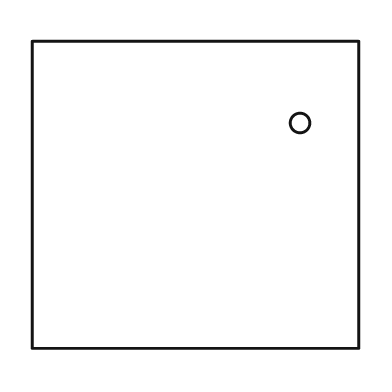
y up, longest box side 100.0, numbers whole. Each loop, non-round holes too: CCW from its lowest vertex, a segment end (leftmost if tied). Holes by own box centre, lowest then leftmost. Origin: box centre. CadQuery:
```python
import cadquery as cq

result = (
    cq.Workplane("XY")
    .moveTo(-50.0, -47.0)
    .lineTo(50.0, -47.0)
    .lineTo(50.0, 47.0)
    .lineTo(-50.0, 47.0)
    .close()
    .moveTo(32.0, 22.0)
    .circle(3.0)
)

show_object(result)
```